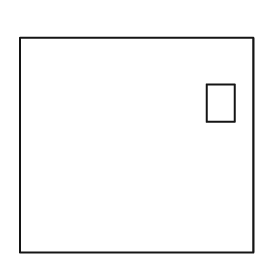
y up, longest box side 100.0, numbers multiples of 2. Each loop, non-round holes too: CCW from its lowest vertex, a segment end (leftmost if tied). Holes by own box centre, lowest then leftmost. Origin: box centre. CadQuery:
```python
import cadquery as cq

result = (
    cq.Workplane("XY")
    .moveTo(-50.0, -46.0)
    .lineTo(50.0, -46.0)
    .lineTo(50.0, 46.0)
    .lineTo(-50.0, 46.0)
    .close()
    .moveTo(30.0, 10.0)
    .lineTo(42.0, 10.0)
    .lineTo(42.0, 26.0)
    .lineTo(30.0, 26.0)
    .close()
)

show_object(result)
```